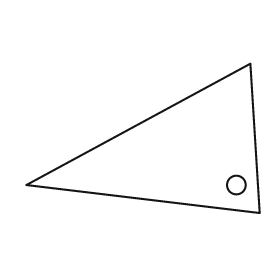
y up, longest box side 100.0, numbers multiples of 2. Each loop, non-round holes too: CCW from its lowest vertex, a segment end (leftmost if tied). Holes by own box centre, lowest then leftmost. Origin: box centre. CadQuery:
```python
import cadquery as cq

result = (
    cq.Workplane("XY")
    .moveTo(50.0, -32.0)
    .lineTo(46.0, 32.0)
    .lineTo(-50.0, -20.0)
    .close()
    .moveTo(40.0, -20.0)
    .circle(4.0)
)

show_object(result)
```